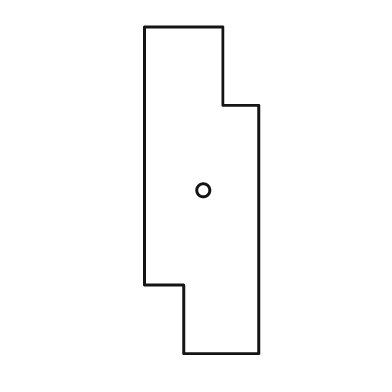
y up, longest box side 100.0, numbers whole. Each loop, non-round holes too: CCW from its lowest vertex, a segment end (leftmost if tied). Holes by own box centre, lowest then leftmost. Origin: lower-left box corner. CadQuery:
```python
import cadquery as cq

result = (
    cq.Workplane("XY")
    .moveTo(12.0, 0.0)
    .lineTo(35.0, 0.0)
    .lineTo(35.0, 76.0)
    .lineTo(24.0, 76.0)
    .lineTo(24.0, 100.0)
    .lineTo(0.0, 100.0)
    .lineTo(0.0, 21.0)
    .lineTo(12.0, 21.0)
    .close()
    .moveTo(18.0, 50.0)
    .circle(2.0)
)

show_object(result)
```